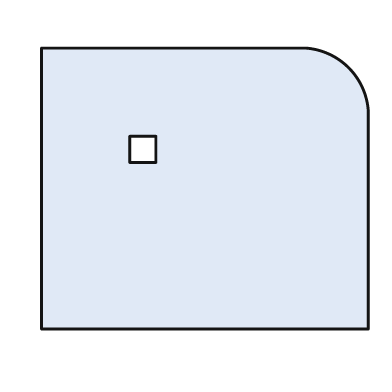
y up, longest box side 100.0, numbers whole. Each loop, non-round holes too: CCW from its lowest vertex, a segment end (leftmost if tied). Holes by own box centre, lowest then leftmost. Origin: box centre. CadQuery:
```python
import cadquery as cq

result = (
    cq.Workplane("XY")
    .moveTo(-50.0, -43.0)
    .lineTo(50.0, -43.0)
    .lineTo(50.0, 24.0)
    .threePointArc((44.0, 37.0), (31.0, 43.0))
    .lineTo(-50.0, 43.0)
    .close()
    .moveTo(-23.0, 8.0)
    .lineTo(-15.0, 8.0)
    .lineTo(-15.0, 16.0)
    .lineTo(-23.0, 16.0)
    .close()
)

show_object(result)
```